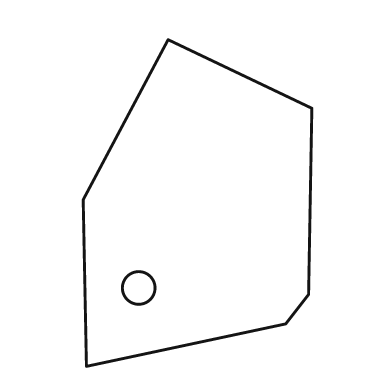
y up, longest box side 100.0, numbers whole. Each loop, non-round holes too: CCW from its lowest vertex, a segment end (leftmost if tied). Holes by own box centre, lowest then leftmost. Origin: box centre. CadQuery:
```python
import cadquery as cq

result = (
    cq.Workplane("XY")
    .moveTo(-34.0, -50.0)
    .lineTo(27.0, -37.0)
    .lineTo(34.0, -28.0)
    .lineTo(35.0, 29.0)
    .lineTo(-9.0, 50.0)
    .lineTo(-35.0, 1.0)
    .close()
    .moveTo(-18.0, -26.0)
    .circle(5.0)
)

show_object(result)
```